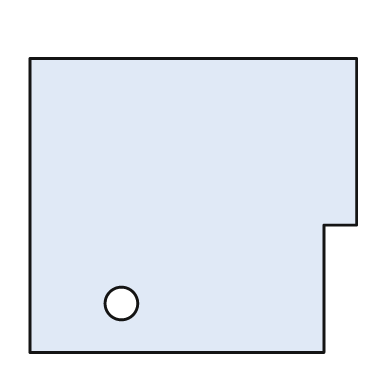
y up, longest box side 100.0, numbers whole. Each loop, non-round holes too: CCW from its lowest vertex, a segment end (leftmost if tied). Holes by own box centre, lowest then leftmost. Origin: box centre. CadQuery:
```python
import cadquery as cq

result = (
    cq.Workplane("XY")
    .moveTo(-50.0, -45.0)
    .lineTo(40.0, -45.0)
    .lineTo(40.0, -6.0)
    .lineTo(50.0, -6.0)
    .lineTo(50.0, 45.0)
    .lineTo(-50.0, 45.0)
    .close()
    .moveTo(-22.0, -30.0)
    .circle(5.0)
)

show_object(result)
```